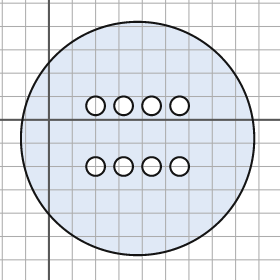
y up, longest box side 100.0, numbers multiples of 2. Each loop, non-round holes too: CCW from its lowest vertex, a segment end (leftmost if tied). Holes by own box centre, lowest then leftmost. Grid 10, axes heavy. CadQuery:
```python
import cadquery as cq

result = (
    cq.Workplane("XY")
    .moveTo(38.0, -8.0)
    .circle(50.0)
    .moveTo(20.0, -20.0)
    .circle(4.0)
    .moveTo(32.0, -20.0)
    .circle(4.0)
    .moveTo(44.0, -20.0)
    .circle(4.0)
    .moveTo(56.0, -20.0)
    .circle(4.0)
    .moveTo(20.0, 6.0)
    .circle(4.0)
    .moveTo(32.0, 6.0)
    .circle(4.0)
    .moveTo(44.0, 6.0)
    .circle(4.0)
    .moveTo(56.0, 6.0)
    .circle(4.0)
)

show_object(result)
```